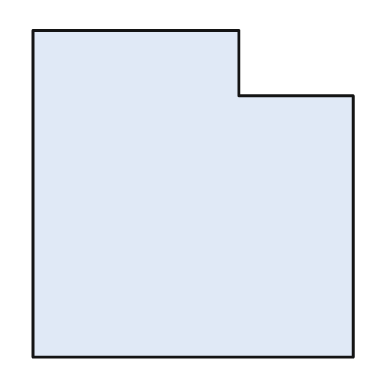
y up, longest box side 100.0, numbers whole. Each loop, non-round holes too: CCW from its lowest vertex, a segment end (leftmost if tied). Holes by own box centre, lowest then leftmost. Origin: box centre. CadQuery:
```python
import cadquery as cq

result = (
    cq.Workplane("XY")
    .moveTo(-49.0, -50.0)
    .lineTo(49.0, -50.0)
    .lineTo(49.0, 30.0)
    .lineTo(14.0, 30.0)
    .lineTo(14.0, 50.0)
    .lineTo(-49.0, 50.0)
    .close()
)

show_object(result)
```